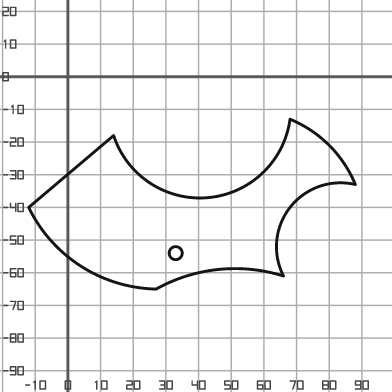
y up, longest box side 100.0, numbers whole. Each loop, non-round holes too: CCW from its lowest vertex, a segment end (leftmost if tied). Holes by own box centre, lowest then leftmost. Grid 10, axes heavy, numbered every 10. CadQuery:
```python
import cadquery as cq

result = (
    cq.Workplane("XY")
    .moveTo(27.0, -65.0)
    .threePointArc((46.0, -59.0), (66.0, -61.0))
    .threePointArc((68.0, -40.0), (88.0, -33.0))
    .threePointArc((80.0, -21.0), (68.0, -13.0))
    .threePointArc((43.0, -37.0), (14.0, -18.0))
    .lineTo(-12.0, -40.0)
    .threePointArc((4.0, -58.0), (27.0, -65.0))
    .close()
    .moveTo(33.0, -54.0)
    .circle(2.0)
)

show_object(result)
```